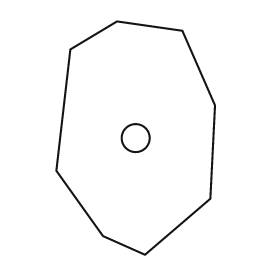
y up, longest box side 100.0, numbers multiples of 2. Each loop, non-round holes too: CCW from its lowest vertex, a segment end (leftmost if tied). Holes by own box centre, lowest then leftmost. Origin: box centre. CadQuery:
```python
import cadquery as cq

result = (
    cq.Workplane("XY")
    .moveTo(4.0, -50.0)
    .lineTo(32.0, -26.0)
    .lineTo(34.0, 14.0)
    .lineTo(20.0, 46.0)
    .lineTo(-8.0, 50.0)
    .lineTo(-28.0, 38.0)
    .lineTo(-34.0, -14.0)
    .lineTo(-14.0, -42.0)
    .close()
    .moveTo(0.0, 0.0)
    .circle(6.0)
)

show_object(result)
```